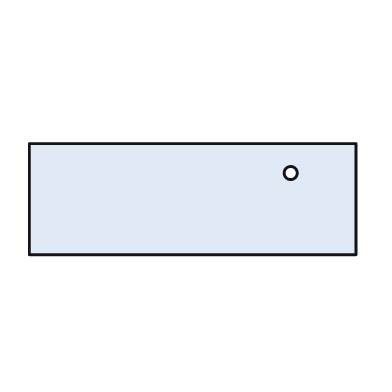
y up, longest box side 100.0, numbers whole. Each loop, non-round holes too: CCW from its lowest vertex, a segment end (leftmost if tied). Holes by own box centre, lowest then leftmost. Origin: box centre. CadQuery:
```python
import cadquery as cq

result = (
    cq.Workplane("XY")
    .moveTo(-50.0, -17.0)
    .lineTo(50.0, -17.0)
    .lineTo(50.0, 17.0)
    .lineTo(-50.0, 17.0)
    .close()
    .moveTo(30.0, 8.0)
    .circle(2.0)
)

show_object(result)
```